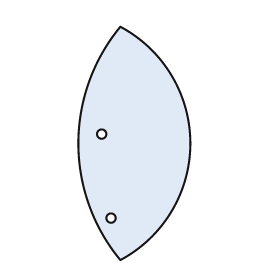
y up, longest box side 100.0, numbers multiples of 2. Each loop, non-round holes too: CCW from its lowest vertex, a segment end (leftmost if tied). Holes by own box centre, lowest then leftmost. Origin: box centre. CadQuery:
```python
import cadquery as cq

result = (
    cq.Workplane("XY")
    .moveTo(-6.0, -50.0)
    .threePointArc((24.0, 0.0), (-6.0, 50.0))
    .threePointArc((-24.0, 0.0), (-6.0, -50.0))
    .close()
    .moveTo(-10.0, -32.0)
    .circle(2.0)
    .moveTo(-14.0, 4.0)
    .circle(2.0)
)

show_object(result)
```